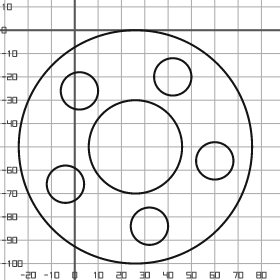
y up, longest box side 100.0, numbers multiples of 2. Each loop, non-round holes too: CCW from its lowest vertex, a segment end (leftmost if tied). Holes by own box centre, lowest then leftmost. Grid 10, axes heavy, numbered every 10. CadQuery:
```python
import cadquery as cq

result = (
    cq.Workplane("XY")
    .moveTo(26.0, -50.0)
    .circle(50.0)
    .moveTo(32.0, -84.0)
    .circle(8.0)
    .moveTo(-4.0, -66.0)
    .circle(8.0)
    .moveTo(60.0, -56.0)
    .circle(8.0)
    .moveTo(26.0, -50.0)
    .circle(20.0)
    .moveTo(2.0, -26.0)
    .circle(8.0)
    .moveTo(42.0, -20.0)
    .circle(8.0)
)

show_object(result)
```